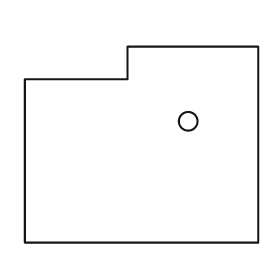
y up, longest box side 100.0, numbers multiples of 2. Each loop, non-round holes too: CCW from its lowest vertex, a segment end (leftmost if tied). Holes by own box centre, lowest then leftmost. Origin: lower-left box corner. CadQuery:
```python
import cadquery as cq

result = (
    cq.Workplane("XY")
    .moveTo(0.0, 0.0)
    .lineTo(100.0, 0.0)
    .lineTo(100.0, 84.0)
    .lineTo(44.0, 84.0)
    .lineTo(44.0, 70.0)
    .lineTo(0.0, 70.0)
    .close()
    .moveTo(70.0, 52.0)
    .circle(4.0)
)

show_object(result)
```